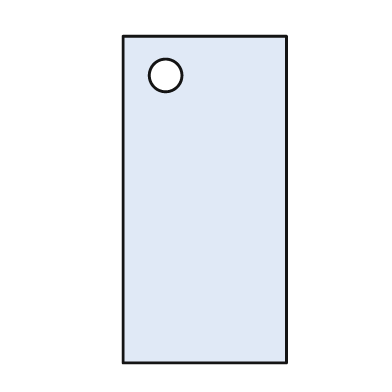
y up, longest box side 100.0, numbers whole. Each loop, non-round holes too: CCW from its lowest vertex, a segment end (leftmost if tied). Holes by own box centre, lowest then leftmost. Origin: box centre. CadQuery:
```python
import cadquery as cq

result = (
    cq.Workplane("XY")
    .moveTo(-25.0, -50.0)
    .lineTo(25.0, -50.0)
    .lineTo(25.0, 50.0)
    .lineTo(-25.0, 50.0)
    .close()
    .moveTo(-12.0, 38.0)
    .circle(5.0)
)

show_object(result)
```